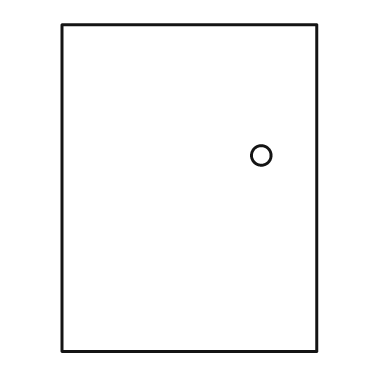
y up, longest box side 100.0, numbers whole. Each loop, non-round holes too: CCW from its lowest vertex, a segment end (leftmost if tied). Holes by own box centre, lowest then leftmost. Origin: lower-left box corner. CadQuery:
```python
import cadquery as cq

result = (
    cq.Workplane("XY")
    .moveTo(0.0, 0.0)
    .lineTo(78.0, 0.0)
    .lineTo(78.0, 100.0)
    .lineTo(0.0, 100.0)
    .close()
    .moveTo(61.0, 60.0)
    .circle(3.0)
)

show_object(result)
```